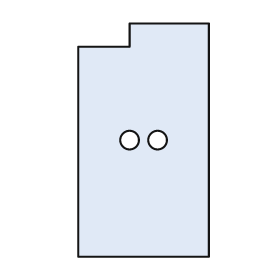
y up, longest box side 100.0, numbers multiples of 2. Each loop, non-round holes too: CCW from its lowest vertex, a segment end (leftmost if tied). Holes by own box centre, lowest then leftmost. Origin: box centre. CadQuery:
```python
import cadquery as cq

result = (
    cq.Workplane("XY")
    .moveTo(-28.0, -50.0)
    .lineTo(28.0, -50.0)
    .lineTo(28.0, 50.0)
    .lineTo(-6.0, 50.0)
    .lineTo(-6.0, 40.0)
    .lineTo(-28.0, 40.0)
    .close()
    .moveTo(-6.0, 0.0)
    .circle(4.0)
    .moveTo(6.0, 0.0)
    .circle(4.0)
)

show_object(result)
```